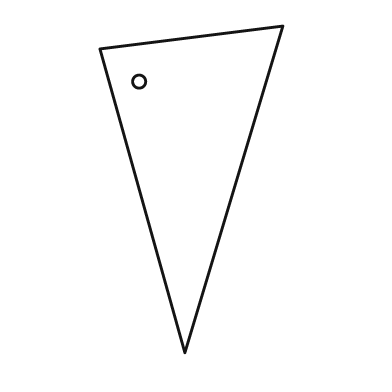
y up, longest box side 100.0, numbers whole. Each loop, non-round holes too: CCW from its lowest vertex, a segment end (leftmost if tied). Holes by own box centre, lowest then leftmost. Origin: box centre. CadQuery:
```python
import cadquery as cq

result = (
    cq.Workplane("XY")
    .moveTo(-2.0, -50.0)
    .lineTo(28.0, 50.0)
    .lineTo(-28.0, 43.0)
    .close()
    .moveTo(-16.0, 33.0)
    .circle(2.0)
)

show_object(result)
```